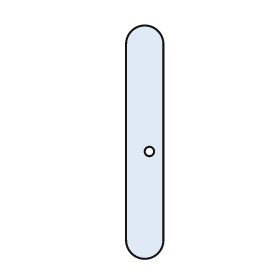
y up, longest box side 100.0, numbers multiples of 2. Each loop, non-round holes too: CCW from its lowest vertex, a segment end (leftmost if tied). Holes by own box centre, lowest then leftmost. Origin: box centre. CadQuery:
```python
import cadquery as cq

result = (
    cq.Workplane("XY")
    .moveTo(-8.0, -42.0)
    .threePointArc((0.0, -50.0), (8.0, -42.0))
    .lineTo(8.0, 42.0)
    .threePointArc((0.0, 50.0), (-8.0, 42.0))
    .close()
    .moveTo(2.0, -4.0)
    .circle(2.0)
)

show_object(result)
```